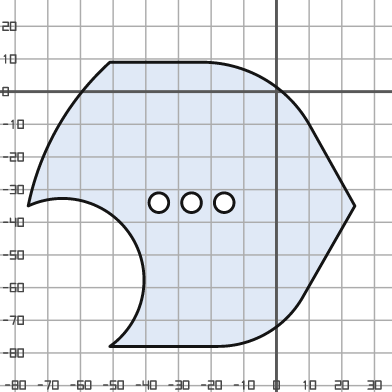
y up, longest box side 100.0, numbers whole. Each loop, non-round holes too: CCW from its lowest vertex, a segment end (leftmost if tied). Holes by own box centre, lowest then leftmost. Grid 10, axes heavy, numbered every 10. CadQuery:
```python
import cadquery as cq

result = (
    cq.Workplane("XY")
    .moveTo(-51.0, -78.0)
    .lineTo(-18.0, -78.0)
    .threePointArc((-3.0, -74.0), (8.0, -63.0))
    .lineTo(24.0, -35.0)
    .lineTo(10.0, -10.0)
    .threePointArc((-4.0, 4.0), (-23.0, 9.0))
    .lineTo(-51.0, 9.0)
    .threePointArc((-67.0, -11.0), (-76.0, -35.0))
    .threePointArc((-44.0, -45.0), (-51.0, -78.0))
    .close()
    .moveTo(-36.0, -34.0)
    .circle(3.0)
    .moveTo(-26.0, -34.0)
    .circle(3.0)
    .moveTo(-16.0, -34.0)
    .circle(3.0)
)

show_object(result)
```